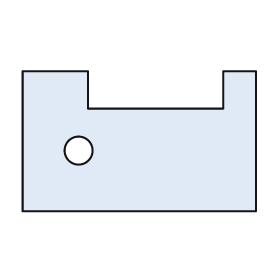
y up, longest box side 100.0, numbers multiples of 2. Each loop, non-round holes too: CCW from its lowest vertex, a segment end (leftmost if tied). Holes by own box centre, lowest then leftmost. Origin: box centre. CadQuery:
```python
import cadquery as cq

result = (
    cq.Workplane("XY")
    .moveTo(-50.0, -30.0)
    .lineTo(50.0, -30.0)
    .lineTo(50.0, 30.0)
    .lineTo(36.0, 30.0)
    .lineTo(36.0, 14.0)
    .lineTo(-22.0, 14.0)
    .lineTo(-22.0, 30.0)
    .lineTo(-50.0, 30.0)
    .close()
    .moveTo(-26.0, -4.0)
    .circle(6.0)
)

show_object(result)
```